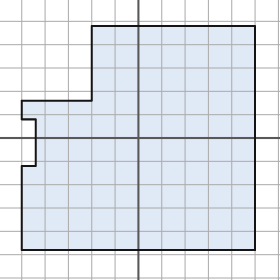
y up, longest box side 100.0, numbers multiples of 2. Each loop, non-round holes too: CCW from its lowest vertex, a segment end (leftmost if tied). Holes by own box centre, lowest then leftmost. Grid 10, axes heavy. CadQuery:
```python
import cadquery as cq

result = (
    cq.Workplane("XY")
    .moveTo(-50.0, -48.0)
    .lineTo(50.0, -48.0)
    .lineTo(50.0, 48.0)
    .lineTo(-20.0, 48.0)
    .lineTo(-20.0, 16.0)
    .lineTo(-50.0, 16.0)
    .lineTo(-50.0, 8.0)
    .lineTo(-44.0, 8.0)
    .lineTo(-44.0, -12.0)
    .lineTo(-50.0, -12.0)
    .close()
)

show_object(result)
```